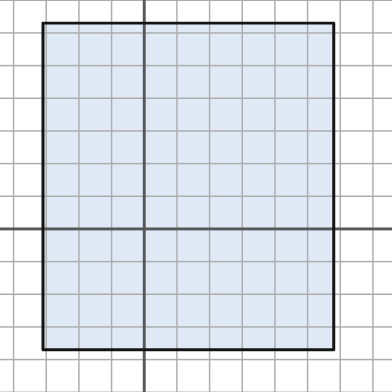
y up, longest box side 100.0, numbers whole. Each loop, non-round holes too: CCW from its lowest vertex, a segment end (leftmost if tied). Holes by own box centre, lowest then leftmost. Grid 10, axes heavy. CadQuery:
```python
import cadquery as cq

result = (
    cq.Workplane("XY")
    .moveTo(-31.0, -37.0)
    .lineTo(58.0, -37.0)
    .lineTo(58.0, 63.0)
    .lineTo(-31.0, 63.0)
    .close()
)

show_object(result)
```